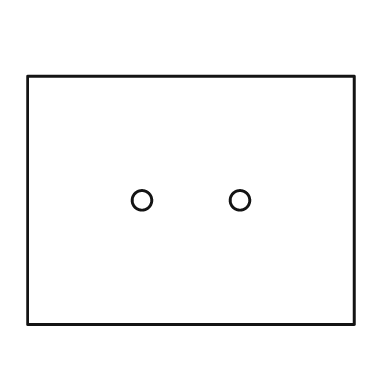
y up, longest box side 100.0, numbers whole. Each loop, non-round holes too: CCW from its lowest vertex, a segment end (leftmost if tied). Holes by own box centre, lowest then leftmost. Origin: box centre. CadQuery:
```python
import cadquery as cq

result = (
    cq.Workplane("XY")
    .moveTo(-50.0, -38.0)
    .lineTo(50.0, -38.0)
    .lineTo(50.0, 38.0)
    .lineTo(-50.0, 38.0)
    .close()
    .moveTo(-15.0, 0.0)
    .circle(3.0)
    .moveTo(15.0, 0.0)
    .circle(3.0)
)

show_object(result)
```